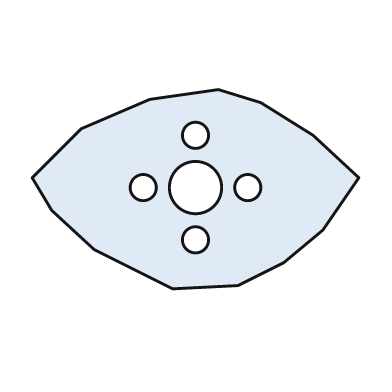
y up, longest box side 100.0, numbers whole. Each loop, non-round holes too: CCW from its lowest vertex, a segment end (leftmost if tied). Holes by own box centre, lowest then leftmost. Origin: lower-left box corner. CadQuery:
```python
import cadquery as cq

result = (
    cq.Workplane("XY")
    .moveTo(43.0, 0.0)
    .lineTo(63.0, 1.0)
    .lineTo(77.0, 8.0)
    .lineTo(89.0, 18.0)
    .lineTo(100.0, 34.0)
    .lineTo(86.0, 47.0)
    .lineTo(70.0, 57.0)
    .lineTo(57.0, 61.0)
    .lineTo(36.0, 58.0)
    .lineTo(15.0, 49.0)
    .lineTo(0.0, 34.0)
    .lineTo(6.0, 24.0)
    .lineTo(19.0, 12.0)
    .close()
    .moveTo(50.0, 15.0)
    .circle(4.0)
    .moveTo(34.0, 31.0)
    .circle(4.0)
    .moveTo(50.0, 31.0)
    .circle(8.0)
    .moveTo(66.0, 31.0)
    .circle(4.0)
    .moveTo(50.0, 47.0)
    .circle(4.0)
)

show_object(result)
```